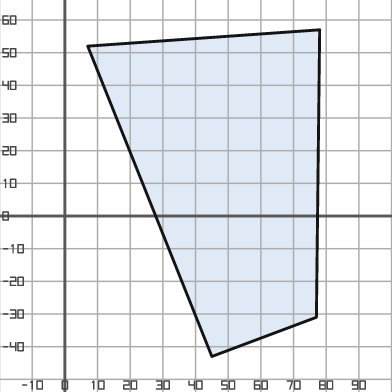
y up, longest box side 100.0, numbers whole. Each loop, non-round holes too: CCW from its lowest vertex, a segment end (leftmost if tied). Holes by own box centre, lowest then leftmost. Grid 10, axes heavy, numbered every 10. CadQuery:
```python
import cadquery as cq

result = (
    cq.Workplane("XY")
    .moveTo(45.0, -43.0)
    .lineTo(77.0, -31.0)
    .lineTo(78.0, 57.0)
    .lineTo(7.0, 52.0)
    .close()
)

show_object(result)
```